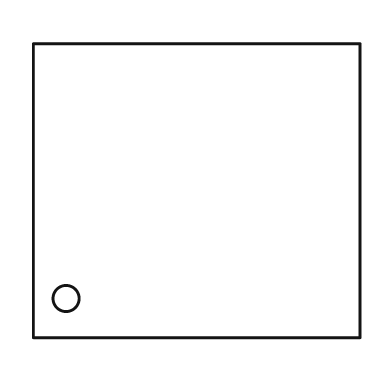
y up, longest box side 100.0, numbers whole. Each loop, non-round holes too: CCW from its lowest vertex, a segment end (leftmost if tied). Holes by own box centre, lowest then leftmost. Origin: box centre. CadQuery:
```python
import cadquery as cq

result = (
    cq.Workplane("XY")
    .moveTo(-50.0, -45.0)
    .lineTo(50.0, -45.0)
    .lineTo(50.0, 45.0)
    .lineTo(-50.0, 45.0)
    .close()
    .moveTo(-40.0, -33.0)
    .circle(4.0)
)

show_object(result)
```